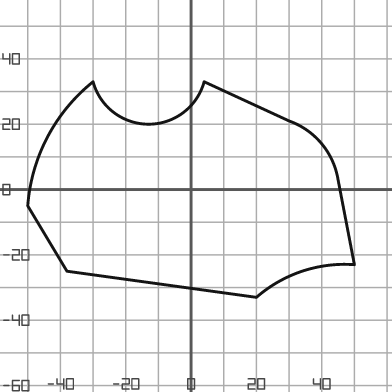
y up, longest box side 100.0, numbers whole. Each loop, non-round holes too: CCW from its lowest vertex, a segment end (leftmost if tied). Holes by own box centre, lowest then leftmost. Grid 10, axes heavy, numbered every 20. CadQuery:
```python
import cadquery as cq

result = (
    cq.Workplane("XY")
    .moveTo(20.0, -33.0)
    .threePointArc((34.0, -25.0), (50.0, -23.0))
    .lineTo(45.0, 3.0)
    .threePointArc((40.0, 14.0), (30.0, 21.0))
    .lineTo(4.0, 33.0)
    .threePointArc((-13.0, 20.0), (-30.0, 33.0))
    .threePointArc((-44.0, 16.0), (-50.0, -5.0))
    .lineTo(-38.0, -25.0)
    .close()
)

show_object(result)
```